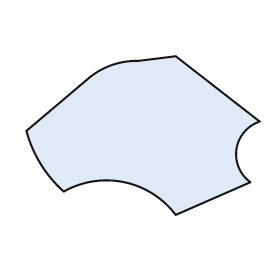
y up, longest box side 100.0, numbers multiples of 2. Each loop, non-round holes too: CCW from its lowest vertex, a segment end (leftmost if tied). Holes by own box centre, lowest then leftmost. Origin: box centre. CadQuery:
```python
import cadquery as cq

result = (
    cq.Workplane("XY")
    .moveTo(14.0, -34.0)
    .lineTo(46.0, -20.0)
    .threePointArc((40.0, -6.0), (50.0, 6.0))
    .lineTo(14.0, 34.0)
    .lineTo(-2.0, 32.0)
    .threePointArc((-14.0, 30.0), (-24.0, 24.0))
    .lineTo(-50.0, 2.0)
    .threePointArc((-44.0, -12.0), (-34.0, -24.0))
    .threePointArc((-8.0, -20.0), (14.0, -34.0))
    .close()
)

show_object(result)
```